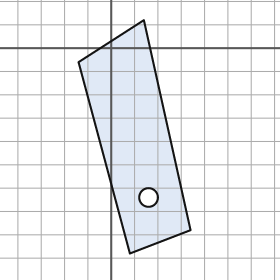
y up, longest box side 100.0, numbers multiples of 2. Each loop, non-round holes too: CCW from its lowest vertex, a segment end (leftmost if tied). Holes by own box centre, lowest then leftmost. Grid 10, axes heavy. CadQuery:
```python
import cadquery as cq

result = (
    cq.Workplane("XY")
    .moveTo(8.0, -88.0)
    .lineTo(34.0, -78.0)
    .lineTo(14.0, 12.0)
    .lineTo(-14.0, -6.0)
    .close()
    .moveTo(16.0, -64.0)
    .circle(4.0)
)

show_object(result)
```